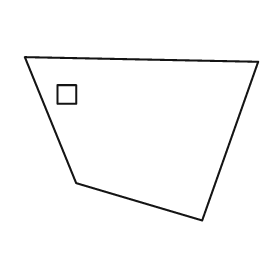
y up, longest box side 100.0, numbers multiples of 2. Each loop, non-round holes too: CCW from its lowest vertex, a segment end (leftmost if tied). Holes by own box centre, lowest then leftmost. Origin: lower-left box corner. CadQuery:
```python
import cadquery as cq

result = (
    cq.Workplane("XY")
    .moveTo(76.0, 0.0)
    .lineTo(100.0, 68.0)
    .lineTo(0.0, 70.0)
    .lineTo(22.0, 16.0)
    .close()
    .moveTo(14.0, 50.0)
    .lineTo(22.0, 50.0)
    .lineTo(22.0, 58.0)
    .lineTo(14.0, 58.0)
    .close()
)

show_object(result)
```